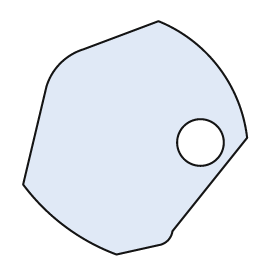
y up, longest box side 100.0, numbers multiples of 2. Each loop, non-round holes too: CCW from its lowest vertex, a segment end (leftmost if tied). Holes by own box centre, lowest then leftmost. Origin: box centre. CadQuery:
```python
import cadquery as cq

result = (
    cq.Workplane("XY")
    .moveTo(-8.0, -50.0)
    .lineTo(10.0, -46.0)
    .threePointArc((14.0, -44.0), (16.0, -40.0))
    .lineTo(48.0, 0.0)
    .threePointArc((36.0, 30.0), (10.0, 50.0))
    .lineTo(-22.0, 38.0)
    .threePointArc((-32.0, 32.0), (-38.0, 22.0))
    .lineTo(-48.0, -20.0)
    .threePointArc((-30.0, -38.0), (-8.0, -50.0))
    .close()
    .moveTo(28.0, -2.0)
    .circle(10.0)
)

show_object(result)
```